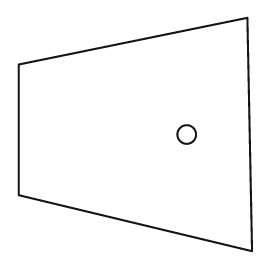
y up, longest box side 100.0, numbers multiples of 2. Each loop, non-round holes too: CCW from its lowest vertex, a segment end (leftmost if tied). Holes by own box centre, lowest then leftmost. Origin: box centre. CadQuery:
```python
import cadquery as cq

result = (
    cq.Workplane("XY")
    .moveTo(50.0, -50.0)
    .lineTo(48.0, 50.0)
    .lineTo(-50.0, 30.0)
    .lineTo(-50.0, -26.0)
    .close()
    .moveTo(22.0, 0.0)
    .circle(4.0)
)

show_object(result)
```